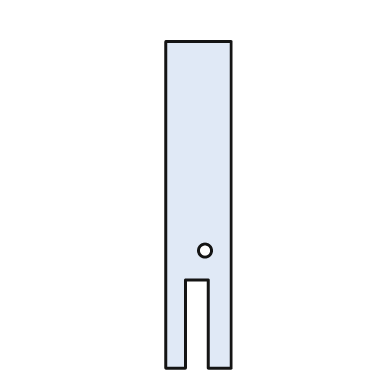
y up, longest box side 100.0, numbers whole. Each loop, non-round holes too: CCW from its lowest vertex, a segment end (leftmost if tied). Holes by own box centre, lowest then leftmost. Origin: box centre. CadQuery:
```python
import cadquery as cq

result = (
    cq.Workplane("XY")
    .moveTo(-10.0, -50.0)
    .lineTo(-4.0, -50.0)
    .lineTo(-4.0, -23.0)
    .lineTo(3.0, -23.0)
    .lineTo(3.0, -50.0)
    .lineTo(10.0, -50.0)
    .lineTo(10.0, 50.0)
    .lineTo(-10.0, 50.0)
    .close()
    .moveTo(2.0, -14.0)
    .circle(2.0)
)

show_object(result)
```